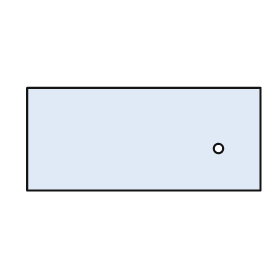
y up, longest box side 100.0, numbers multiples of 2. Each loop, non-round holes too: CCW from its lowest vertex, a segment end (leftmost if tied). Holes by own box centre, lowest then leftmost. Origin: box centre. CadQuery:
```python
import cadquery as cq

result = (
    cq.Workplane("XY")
    .moveTo(-50.0, -22.0)
    .lineTo(50.0, -22.0)
    .lineTo(50.0, 22.0)
    .lineTo(-50.0, 22.0)
    .close()
    .moveTo(32.0, -4.0)
    .circle(2.0)
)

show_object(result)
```